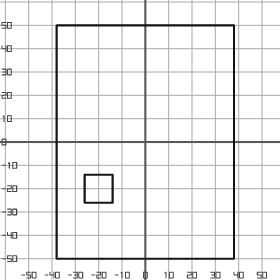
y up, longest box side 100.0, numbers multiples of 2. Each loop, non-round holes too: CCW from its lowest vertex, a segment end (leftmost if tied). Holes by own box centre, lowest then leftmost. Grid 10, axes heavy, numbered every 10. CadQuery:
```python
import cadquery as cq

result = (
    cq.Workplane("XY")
    .moveTo(-38.0, -50.0)
    .lineTo(38.0, -50.0)
    .lineTo(38.0, 50.0)
    .lineTo(-38.0, 50.0)
    .close()
    .moveTo(-26.0, -26.0)
    .lineTo(-14.0, -26.0)
    .lineTo(-14.0, -14.0)
    .lineTo(-26.0, -14.0)
    .close()
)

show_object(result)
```